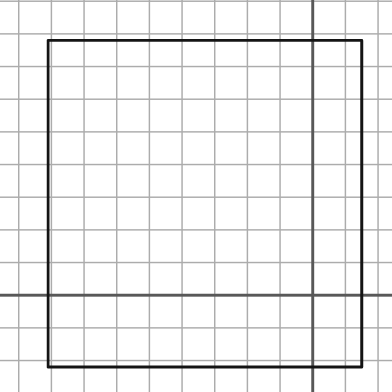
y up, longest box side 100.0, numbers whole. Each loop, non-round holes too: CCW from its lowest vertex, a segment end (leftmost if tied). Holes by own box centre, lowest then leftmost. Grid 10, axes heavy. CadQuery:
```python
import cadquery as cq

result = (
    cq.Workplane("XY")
    .moveTo(-81.0, -22.0)
    .lineTo(15.0, -22.0)
    .lineTo(15.0, 78.0)
    .lineTo(-81.0, 78.0)
    .close()
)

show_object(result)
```